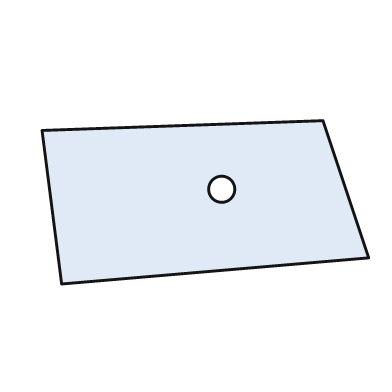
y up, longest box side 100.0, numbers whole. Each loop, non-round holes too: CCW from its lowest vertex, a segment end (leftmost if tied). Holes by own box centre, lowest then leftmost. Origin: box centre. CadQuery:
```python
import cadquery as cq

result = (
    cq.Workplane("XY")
    .moveTo(-44.0, -25.0)
    .lineTo(50.0, -17.0)
    .lineTo(36.0, 25.0)
    .lineTo(-50.0, 22.0)
    .close()
    .moveTo(5.0, 4.0)
    .circle(4.0)
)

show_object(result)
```